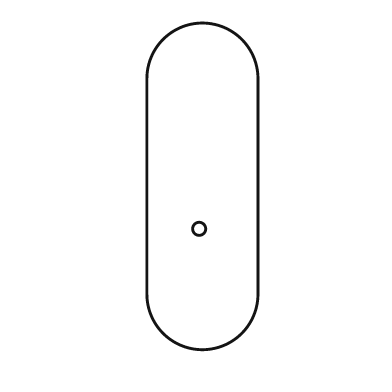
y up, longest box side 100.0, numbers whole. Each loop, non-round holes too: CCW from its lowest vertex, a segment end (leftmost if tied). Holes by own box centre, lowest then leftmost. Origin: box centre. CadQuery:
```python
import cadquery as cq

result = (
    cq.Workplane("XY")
    .moveTo(-17.0, -33.0)
    .threePointArc((0.0, -50.0), (17.0, -33.0))
    .lineTo(17.0, 33.0)
    .threePointArc((0.0, 50.0), (-17.0, 33.0))
    .close()
    .moveTo(-1.0, -13.0)
    .circle(2.0)
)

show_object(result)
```